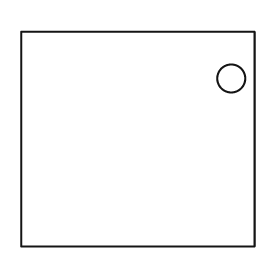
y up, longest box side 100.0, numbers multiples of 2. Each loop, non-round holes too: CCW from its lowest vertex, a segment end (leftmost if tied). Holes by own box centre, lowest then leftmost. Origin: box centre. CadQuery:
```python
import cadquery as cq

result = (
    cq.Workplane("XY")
    .moveTo(-50.0, -46.0)
    .lineTo(50.0, -46.0)
    .lineTo(50.0, 46.0)
    .lineTo(-50.0, 46.0)
    .close()
    .moveTo(40.0, 26.0)
    .circle(6.0)
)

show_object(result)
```